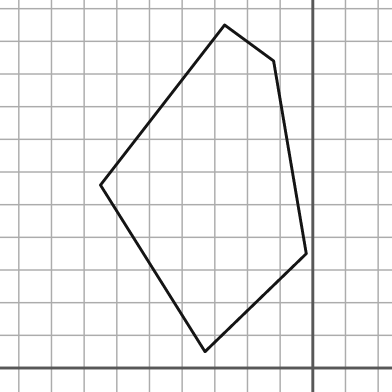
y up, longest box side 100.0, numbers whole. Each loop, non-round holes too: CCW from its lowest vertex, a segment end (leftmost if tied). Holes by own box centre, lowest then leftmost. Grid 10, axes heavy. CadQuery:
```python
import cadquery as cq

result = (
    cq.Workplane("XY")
    .moveTo(-33.0, 5.0)
    .lineTo(-2.0, 35.0)
    .lineTo(-12.0, 94.0)
    .lineTo(-27.0, 105.0)
    .lineTo(-65.0, 56.0)
    .close()
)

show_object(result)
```